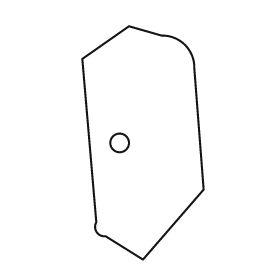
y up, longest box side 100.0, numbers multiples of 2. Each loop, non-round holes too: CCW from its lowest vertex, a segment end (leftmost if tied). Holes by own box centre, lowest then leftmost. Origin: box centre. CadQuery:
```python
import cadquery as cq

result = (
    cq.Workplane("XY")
    .moveTo(0.0, -50.0)
    .lineTo(26.0, -20.0)
    .lineTo(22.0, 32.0)
    .threePointArc((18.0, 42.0), (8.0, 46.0))
    .lineTo(-6.0, 50.0)
    .lineTo(-26.0, 36.0)
    .lineTo(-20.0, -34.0)
    .threePointArc((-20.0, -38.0), (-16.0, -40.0))
    .close()
    .moveTo(-10.0, 0.0)
    .circle(4.0)
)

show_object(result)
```